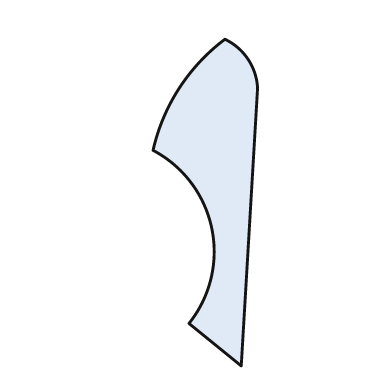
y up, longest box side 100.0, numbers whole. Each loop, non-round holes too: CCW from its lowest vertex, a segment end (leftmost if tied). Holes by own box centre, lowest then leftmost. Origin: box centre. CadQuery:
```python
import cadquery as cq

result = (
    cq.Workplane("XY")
    .moveTo(11.0, -50.0)
    .lineTo(16.0, 35.0)
    .threePointArc((13.0, 44.0), (6.0, 50.0))
    .threePointArc((-8.0, 35.0), (-16.0, 16.0))
    .threePointArc((2.0, -8.0), (-5.0, -37.0))
    .close()
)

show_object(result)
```